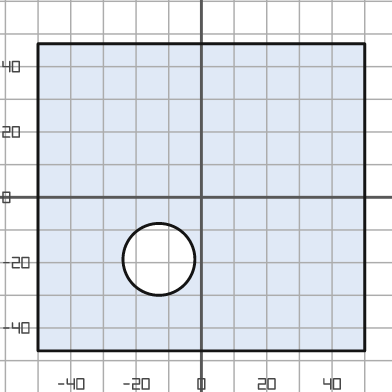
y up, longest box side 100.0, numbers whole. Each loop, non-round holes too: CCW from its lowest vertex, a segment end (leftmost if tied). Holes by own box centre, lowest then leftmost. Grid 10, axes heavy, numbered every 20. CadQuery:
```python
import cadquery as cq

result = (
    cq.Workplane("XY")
    .moveTo(-50.0, -47.0)
    .lineTo(50.0, -47.0)
    .lineTo(50.0, 47.0)
    .lineTo(-50.0, 47.0)
    .close()
    .moveTo(-13.0, -19.0)
    .circle(11.0)
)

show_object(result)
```